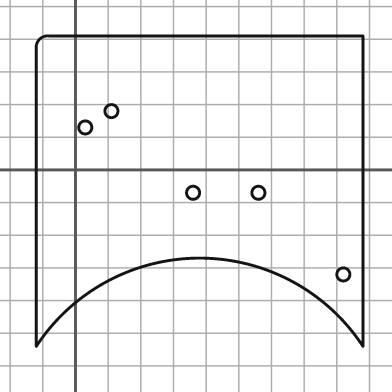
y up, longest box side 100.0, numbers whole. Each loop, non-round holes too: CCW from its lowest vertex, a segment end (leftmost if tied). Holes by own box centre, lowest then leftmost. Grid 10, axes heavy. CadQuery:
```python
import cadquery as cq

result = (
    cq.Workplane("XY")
    .moveTo(-12.0, -54.0)
    .threePointArc((38.0, -27.0), (88.0, -54.0))
    .lineTo(88.0, 41.0)
    .lineTo(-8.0, 41.0)
    .threePointArc((-11.0, 40.0), (-12.0, 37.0))
    .close()
    .moveTo(82.0, -32.0)
    .circle(2.0)
    .moveTo(36.0, -7.0)
    .circle(2.0)
    .moveTo(56.0, -7.0)
    .circle(2.0)
    .moveTo(3.0, 13.0)
    .circle(2.0)
    .moveTo(11.0, 18.0)
    .circle(2.0)
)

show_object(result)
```